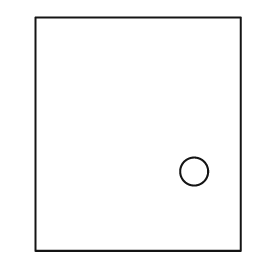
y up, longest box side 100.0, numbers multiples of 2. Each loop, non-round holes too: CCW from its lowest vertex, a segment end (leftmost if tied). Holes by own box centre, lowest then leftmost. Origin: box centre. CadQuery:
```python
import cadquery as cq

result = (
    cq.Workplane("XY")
    .moveTo(-44.0, -50.0)
    .lineTo(44.0, -50.0)
    .lineTo(44.0, 50.0)
    .lineTo(-44.0, 50.0)
    .close()
    .moveTo(24.0, -16.0)
    .circle(6.0)
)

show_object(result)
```